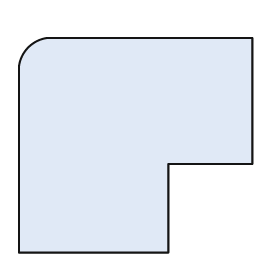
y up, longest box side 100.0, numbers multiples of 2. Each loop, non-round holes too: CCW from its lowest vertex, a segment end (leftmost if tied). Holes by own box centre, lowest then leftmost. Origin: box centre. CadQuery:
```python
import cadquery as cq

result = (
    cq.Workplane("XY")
    .moveTo(-50.0, -46.0)
    .lineTo(14.0, -46.0)
    .lineTo(14.0, -8.0)
    .lineTo(50.0, -8.0)
    .lineTo(50.0, 46.0)
    .lineTo(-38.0, 46.0)
    .threePointArc((-46.0, 42.0), (-50.0, 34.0))
    .close()
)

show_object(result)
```